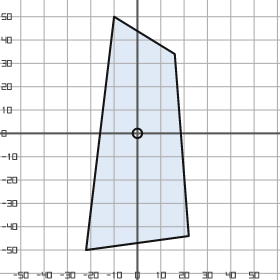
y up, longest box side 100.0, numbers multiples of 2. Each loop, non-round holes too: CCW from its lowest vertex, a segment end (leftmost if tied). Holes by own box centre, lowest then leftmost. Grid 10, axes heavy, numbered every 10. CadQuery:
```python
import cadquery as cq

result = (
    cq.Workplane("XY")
    .moveTo(-22.0, -50.0)
    .lineTo(22.0, -44.0)
    .lineTo(16.0, 34.0)
    .lineTo(-10.0, 50.0)
    .close()
    .moveTo(0.0, 0.0)
    .circle(2.0)
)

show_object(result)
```